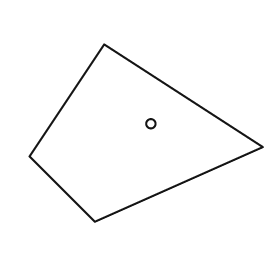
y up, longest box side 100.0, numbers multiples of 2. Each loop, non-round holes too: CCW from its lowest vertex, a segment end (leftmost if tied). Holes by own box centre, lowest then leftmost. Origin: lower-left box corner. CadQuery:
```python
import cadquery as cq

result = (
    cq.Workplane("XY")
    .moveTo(28.0, 0.0)
    .lineTo(100.0, 32.0)
    .lineTo(32.0, 76.0)
    .lineTo(0.0, 28.0)
    .close()
    .moveTo(52.0, 42.0)
    .circle(2.0)
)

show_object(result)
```